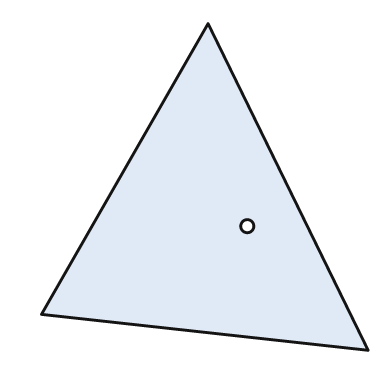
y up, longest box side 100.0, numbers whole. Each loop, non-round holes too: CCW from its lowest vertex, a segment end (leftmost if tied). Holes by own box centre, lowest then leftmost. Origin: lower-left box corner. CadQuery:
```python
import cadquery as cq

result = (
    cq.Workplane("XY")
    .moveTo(100.0, 0.0)
    .lineTo(51.0, 100.0)
    .lineTo(0.0, 11.0)
    .close()
    .moveTo(63.0, 38.0)
    .circle(2.0)
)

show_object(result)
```